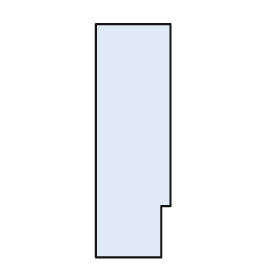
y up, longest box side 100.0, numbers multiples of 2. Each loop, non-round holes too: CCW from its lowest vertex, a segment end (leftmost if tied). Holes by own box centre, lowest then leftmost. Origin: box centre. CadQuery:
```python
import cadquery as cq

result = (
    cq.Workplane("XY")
    .moveTo(-16.0, -50.0)
    .lineTo(12.0, -50.0)
    .lineTo(12.0, -28.0)
    .lineTo(16.0, -28.0)
    .lineTo(16.0, 50.0)
    .lineTo(-16.0, 50.0)
    .close()
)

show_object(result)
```